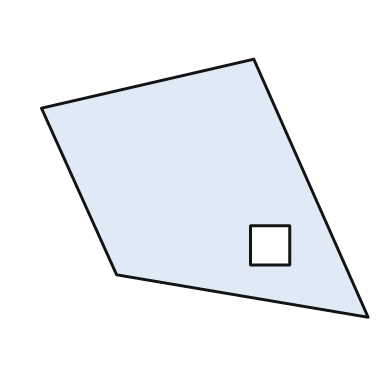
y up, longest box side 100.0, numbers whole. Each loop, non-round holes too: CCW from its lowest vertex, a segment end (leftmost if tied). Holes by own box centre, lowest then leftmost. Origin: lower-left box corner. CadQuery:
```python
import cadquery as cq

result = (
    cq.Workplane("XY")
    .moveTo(100.0, 0.0)
    .lineTo(65.0, 79.0)
    .lineTo(0.0, 64.0)
    .lineTo(23.0, 13.0)
    .close()
    .moveTo(64.0, 16.0)
    .lineTo(76.0, 16.0)
    .lineTo(76.0, 28.0)
    .lineTo(64.0, 28.0)
    .close()
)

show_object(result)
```